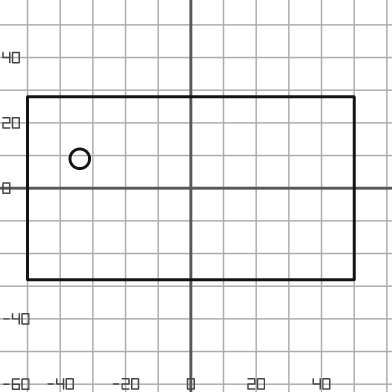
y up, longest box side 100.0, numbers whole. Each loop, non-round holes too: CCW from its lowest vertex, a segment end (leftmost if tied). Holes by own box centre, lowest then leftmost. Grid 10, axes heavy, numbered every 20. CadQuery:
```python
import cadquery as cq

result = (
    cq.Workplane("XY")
    .moveTo(-50.0, -28.0)
    .lineTo(50.0, -28.0)
    .lineTo(50.0, 28.0)
    .lineTo(-50.0, 28.0)
    .close()
    .moveTo(-34.0, 9.0)
    .circle(3.0)
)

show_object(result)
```